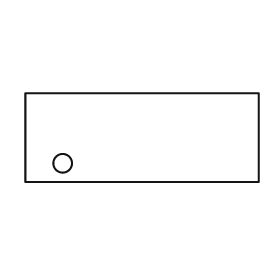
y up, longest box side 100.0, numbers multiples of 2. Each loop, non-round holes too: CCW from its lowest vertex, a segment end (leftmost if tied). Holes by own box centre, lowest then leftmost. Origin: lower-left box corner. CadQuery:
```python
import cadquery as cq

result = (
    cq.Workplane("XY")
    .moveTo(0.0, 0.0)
    .lineTo(100.0, 0.0)
    .lineTo(100.0, 38.0)
    .lineTo(0.0, 38.0)
    .close()
    .moveTo(16.0, 8.0)
    .circle(4.0)
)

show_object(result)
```